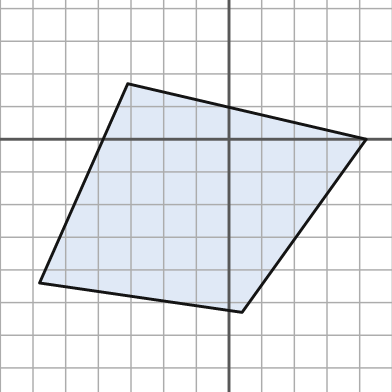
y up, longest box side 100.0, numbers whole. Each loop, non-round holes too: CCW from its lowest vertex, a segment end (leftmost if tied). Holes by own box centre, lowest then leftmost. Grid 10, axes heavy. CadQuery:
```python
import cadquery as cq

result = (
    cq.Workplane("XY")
    .moveTo(4.0, -53.0)
    .lineTo(42.0, 0.0)
    .lineTo(-31.0, 17.0)
    .lineTo(-58.0, -44.0)
    .close()
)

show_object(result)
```